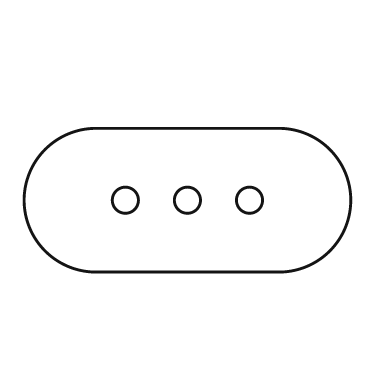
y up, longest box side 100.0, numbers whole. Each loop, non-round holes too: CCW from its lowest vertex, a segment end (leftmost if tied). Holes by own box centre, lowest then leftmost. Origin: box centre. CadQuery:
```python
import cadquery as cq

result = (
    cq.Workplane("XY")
    .moveTo(-28.0, -22.0)
    .lineTo(28.0, -22.0)
    .threePointArc((50.0, 0.0), (28.0, 22.0))
    .lineTo(-28.0, 22.0)
    .threePointArc((-50.0, 0.0), (-28.0, -22.0))
    .close()
    .moveTo(-19.0, 0.0)
    .circle(4.0)
    .moveTo(0.0, 0.0)
    .circle(4.0)
    .moveTo(19.0, 0.0)
    .circle(4.0)
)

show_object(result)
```